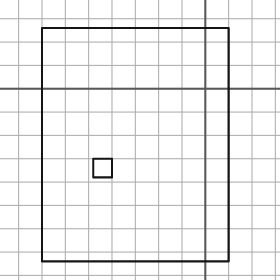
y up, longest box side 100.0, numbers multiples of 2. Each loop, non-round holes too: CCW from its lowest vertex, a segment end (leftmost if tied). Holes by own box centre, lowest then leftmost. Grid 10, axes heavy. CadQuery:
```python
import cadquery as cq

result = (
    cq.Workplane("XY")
    .moveTo(-70.0, -74.0)
    .lineTo(10.0, -74.0)
    .lineTo(10.0, 26.0)
    .lineTo(-70.0, 26.0)
    .close()
    .moveTo(-48.0, -38.0)
    .lineTo(-40.0, -38.0)
    .lineTo(-40.0, -30.0)
    .lineTo(-48.0, -30.0)
    .close()
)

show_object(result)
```